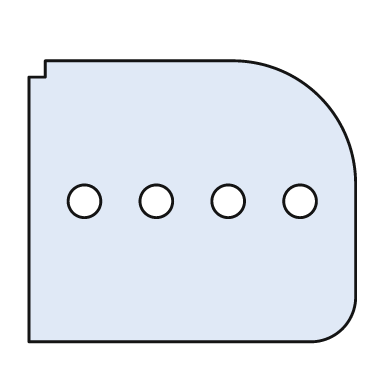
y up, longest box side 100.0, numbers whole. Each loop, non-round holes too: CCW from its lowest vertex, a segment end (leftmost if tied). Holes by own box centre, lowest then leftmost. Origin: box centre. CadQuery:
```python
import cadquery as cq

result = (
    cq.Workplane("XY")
    .moveTo(-50.0, -43.0)
    .lineTo(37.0, -43.0)
    .threePointArc((46.0, -39.0), (50.0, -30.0))
    .lineTo(50.0, 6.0)
    .threePointArc((39.0, 32.0), (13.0, 43.0))
    .lineTo(-45.0, 43.0)
    .lineTo(-45.0, 38.0)
    .lineTo(-50.0, 38.0)
    .close()
    .moveTo(-33.0, 0.0)
    .circle(5.0)
    .moveTo(-11.0, 0.0)
    .circle(5.0)
    .moveTo(11.0, 0.0)
    .circle(5.0)
    .moveTo(33.0, 0.0)
    .circle(5.0)
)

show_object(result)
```